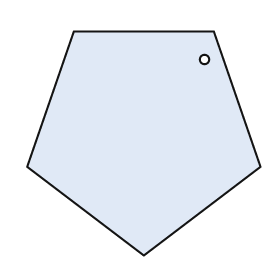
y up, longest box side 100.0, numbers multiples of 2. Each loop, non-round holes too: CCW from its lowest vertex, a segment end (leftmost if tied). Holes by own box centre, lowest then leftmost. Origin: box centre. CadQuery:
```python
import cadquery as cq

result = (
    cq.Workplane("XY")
    .moveTo(0.0, -48.0)
    .lineTo(50.0, -10.0)
    .lineTo(30.0, 48.0)
    .lineTo(-30.0, 48.0)
    .lineTo(-50.0, -10.0)
    .close()
    .moveTo(26.0, 36.0)
    .circle(2.0)
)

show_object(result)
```